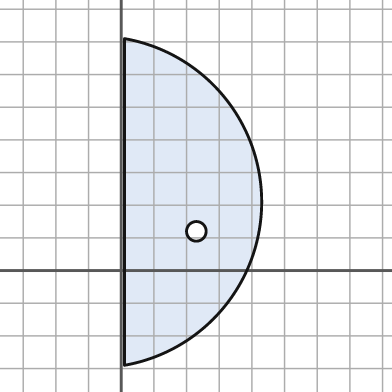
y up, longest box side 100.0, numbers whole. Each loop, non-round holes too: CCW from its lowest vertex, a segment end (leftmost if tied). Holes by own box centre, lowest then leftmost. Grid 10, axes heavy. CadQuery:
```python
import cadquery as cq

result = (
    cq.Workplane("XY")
    .moveTo(1.0, -29.0)
    .threePointArc((43.0, 21.0), (1.0, 71.0))
    .close()
    .moveTo(23.0, 12.0)
    .circle(3.0)
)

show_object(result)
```